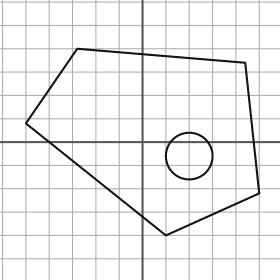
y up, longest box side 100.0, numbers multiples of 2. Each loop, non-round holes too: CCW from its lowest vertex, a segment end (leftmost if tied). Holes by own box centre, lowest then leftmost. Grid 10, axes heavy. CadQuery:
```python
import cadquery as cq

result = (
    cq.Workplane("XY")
    .moveTo(10.0, -40.0)
    .lineTo(50.0, -22.0)
    .lineTo(44.0, 34.0)
    .lineTo(-28.0, 40.0)
    .lineTo(-50.0, 8.0)
    .close()
    .moveTo(20.0, -6.0)
    .circle(10.0)
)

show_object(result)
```